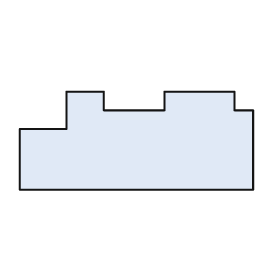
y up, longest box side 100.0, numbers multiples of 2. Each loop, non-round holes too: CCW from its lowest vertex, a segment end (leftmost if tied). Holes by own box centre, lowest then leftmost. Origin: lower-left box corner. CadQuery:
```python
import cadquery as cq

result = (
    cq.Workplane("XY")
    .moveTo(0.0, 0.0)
    .lineTo(100.0, 0.0)
    .lineTo(100.0, 34.0)
    .lineTo(92.0, 34.0)
    .lineTo(92.0, 42.0)
    .lineTo(62.0, 42.0)
    .lineTo(62.0, 34.0)
    .lineTo(36.0, 34.0)
    .lineTo(36.0, 42.0)
    .lineTo(20.0, 42.0)
    .lineTo(20.0, 26.0)
    .lineTo(0.0, 26.0)
    .close()
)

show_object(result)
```